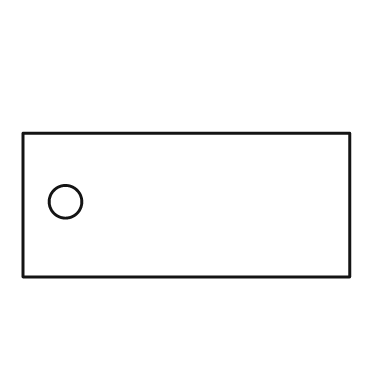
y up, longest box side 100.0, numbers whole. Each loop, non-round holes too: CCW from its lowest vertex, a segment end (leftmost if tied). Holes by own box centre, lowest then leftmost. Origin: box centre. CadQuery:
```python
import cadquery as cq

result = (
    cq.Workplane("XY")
    .moveTo(-50.0, -22.0)
    .lineTo(50.0, -22.0)
    .lineTo(50.0, 22.0)
    .lineTo(-50.0, 22.0)
    .close()
    .moveTo(-37.0, 1.0)
    .circle(5.0)
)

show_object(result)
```